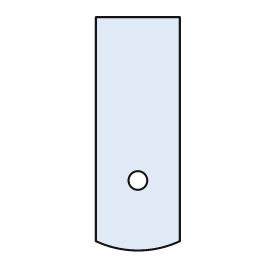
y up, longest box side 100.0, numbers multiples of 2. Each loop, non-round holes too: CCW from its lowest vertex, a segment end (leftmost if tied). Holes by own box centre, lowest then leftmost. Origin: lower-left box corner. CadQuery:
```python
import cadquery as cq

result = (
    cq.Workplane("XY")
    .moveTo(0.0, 4.0)
    .threePointArc((18.0, 0.0), (36.0, 4.0))
    .lineTo(36.0, 100.0)
    .lineTo(0.0, 100.0)
    .close()
    .moveTo(18.0, 30.0)
    .circle(4.0)
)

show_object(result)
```